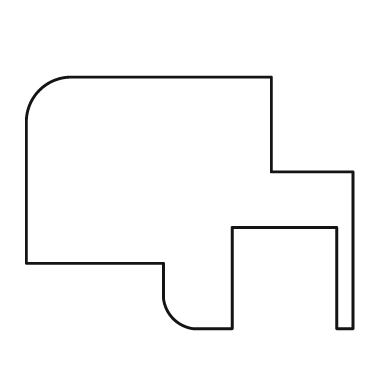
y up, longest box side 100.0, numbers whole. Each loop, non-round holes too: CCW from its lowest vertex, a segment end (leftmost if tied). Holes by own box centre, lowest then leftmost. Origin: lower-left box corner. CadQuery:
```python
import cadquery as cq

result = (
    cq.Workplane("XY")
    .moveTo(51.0, 0.0)
    .lineTo(63.0, 0.0)
    .lineTo(63.0, 31.0)
    .lineTo(95.0, 31.0)
    .lineTo(95.0, 0.0)
    .lineTo(100.0, 0.0)
    .lineTo(100.0, 48.0)
    .lineTo(75.0, 48.0)
    .lineTo(75.0, 77.0)
    .lineTo(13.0, 77.0)
    .threePointArc((4.0, 73.0), (0.0, 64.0))
    .lineTo(0.0, 20.0)
    .lineTo(42.0, 20.0)
    .lineTo(42.0, 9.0)
    .threePointArc((45.0, 3.0), (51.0, 0.0))
    .close()
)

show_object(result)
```